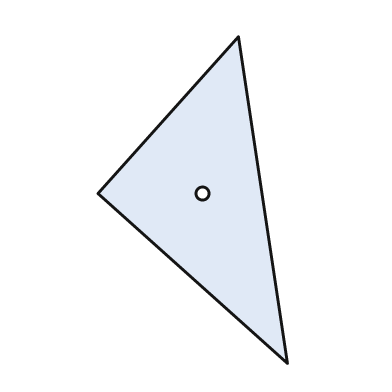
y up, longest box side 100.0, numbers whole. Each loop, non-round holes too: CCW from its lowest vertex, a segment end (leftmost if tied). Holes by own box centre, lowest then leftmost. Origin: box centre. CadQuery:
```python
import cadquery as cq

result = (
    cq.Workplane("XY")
    .moveTo(29.0, -50.0)
    .lineTo(14.0, 50.0)
    .lineTo(-29.0, 2.0)
    .close()
    .moveTo(3.0, 2.0)
    .circle(2.0)
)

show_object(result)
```